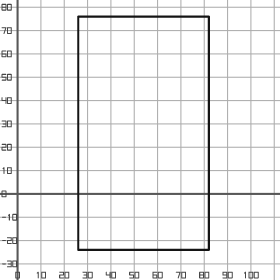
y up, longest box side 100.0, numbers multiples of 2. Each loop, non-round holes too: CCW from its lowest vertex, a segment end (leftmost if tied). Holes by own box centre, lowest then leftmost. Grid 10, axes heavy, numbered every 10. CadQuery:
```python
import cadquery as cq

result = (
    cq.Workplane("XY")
    .moveTo(26.0, -24.0)
    .lineTo(82.0, -24.0)
    .lineTo(82.0, 76.0)
    .lineTo(26.0, 76.0)
    .close()
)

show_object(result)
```